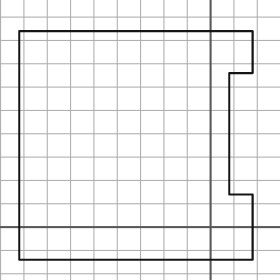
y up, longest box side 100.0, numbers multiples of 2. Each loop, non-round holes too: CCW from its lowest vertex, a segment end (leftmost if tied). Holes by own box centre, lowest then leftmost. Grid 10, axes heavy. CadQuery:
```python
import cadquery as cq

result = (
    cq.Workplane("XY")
    .moveTo(-82.0, -14.0)
    .lineTo(18.0, -14.0)
    .lineTo(18.0, 14.0)
    .lineTo(8.0, 14.0)
    .lineTo(8.0, 66.0)
    .lineTo(18.0, 66.0)
    .lineTo(18.0, 84.0)
    .lineTo(-82.0, 84.0)
    .close()
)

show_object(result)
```